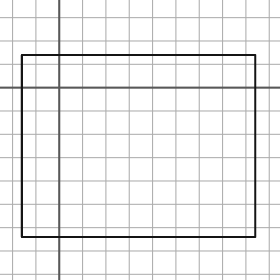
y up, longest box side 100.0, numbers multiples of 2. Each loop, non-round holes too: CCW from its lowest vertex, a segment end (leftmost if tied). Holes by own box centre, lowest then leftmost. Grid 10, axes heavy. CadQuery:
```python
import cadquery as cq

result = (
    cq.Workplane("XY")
    .moveTo(-16.0, -64.0)
    .lineTo(84.0, -64.0)
    .lineTo(84.0, 14.0)
    .lineTo(-16.0, 14.0)
    .close()
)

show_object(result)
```